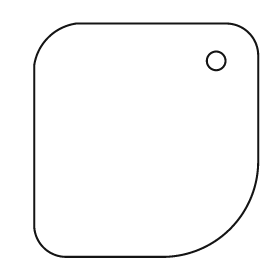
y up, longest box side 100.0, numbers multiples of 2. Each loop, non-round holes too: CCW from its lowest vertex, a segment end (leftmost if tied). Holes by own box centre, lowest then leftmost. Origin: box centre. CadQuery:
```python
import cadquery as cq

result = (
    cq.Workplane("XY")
    .moveTo(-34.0, -50.0)
    .lineTo(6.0, -50.0)
    .threePointArc((36.0, -38.0), (48.0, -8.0))
    .lineTo(48.0, 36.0)
    .threePointArc((44.0, 46.0), (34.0, 50.0))
    .lineTo(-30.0, 50.0)
    .threePointArc((-42.0, 44.0), (-48.0, 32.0))
    .lineTo(-48.0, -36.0)
    .threePointArc((-44.0, -46.0), (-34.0, -50.0))
    .close()
    .moveTo(30.0, 34.0)
    .circle(4.0)
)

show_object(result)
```